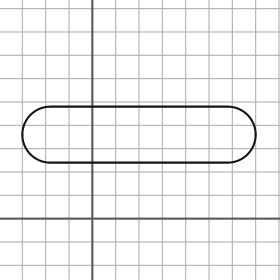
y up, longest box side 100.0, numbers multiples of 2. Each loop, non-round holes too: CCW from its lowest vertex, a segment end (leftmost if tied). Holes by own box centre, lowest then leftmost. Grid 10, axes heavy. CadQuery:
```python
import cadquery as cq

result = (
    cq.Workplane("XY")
    .moveTo(-18.0, 24.0)
    .lineTo(58.0, 24.0)
    .threePointArc((70.0, 36.0), (58.0, 48.0))
    .lineTo(-18.0, 48.0)
    .threePointArc((-30.0, 36.0), (-18.0, 24.0))
    .close()
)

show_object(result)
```